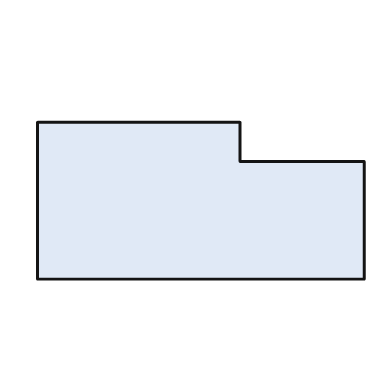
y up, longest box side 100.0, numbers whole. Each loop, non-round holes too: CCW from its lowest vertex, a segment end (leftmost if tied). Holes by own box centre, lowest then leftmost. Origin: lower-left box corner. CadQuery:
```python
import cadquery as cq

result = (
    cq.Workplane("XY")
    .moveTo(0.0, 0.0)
    .lineTo(100.0, 0.0)
    .lineTo(100.0, 36.0)
    .lineTo(62.0, 36.0)
    .lineTo(62.0, 48.0)
    .lineTo(0.0, 48.0)
    .close()
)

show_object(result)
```